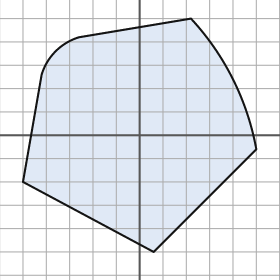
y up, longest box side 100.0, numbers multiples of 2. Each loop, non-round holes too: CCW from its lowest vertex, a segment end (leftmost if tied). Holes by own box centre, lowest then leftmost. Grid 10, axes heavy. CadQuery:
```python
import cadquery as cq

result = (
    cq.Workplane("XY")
    .moveTo(6.0, -50.0)
    .lineTo(50.0, -6.0)
    .threePointArc((40.0, 24.0), (22.0, 50.0))
    .lineTo(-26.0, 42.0)
    .threePointArc((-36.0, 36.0), (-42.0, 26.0))
    .lineTo(-50.0, -20.0)
    .close()
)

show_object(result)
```